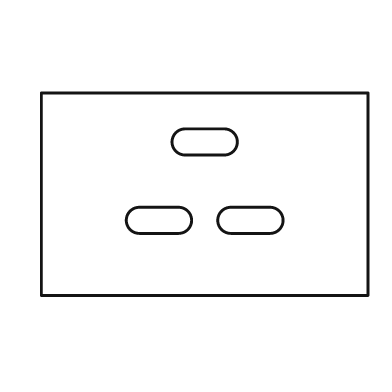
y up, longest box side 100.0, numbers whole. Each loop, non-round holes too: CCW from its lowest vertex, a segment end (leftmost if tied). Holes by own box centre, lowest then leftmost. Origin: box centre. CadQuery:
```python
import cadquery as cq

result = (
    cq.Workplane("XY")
    .moveTo(-50.0, -31.0)
    .lineTo(50.0, -31.0)
    .lineTo(50.0, 31.0)
    .lineTo(-50.0, 31.0)
    .close()
    .moveTo(-20.0, -12.0)
    .lineTo(-8.0, -12.0)
    .threePointArc((-4.0, -8.0), (-8.0, -4.0))
    .lineTo(-20.0, -4.0)
    .threePointArc((-24.0, -8.0), (-20.0, -12.0))
    .close()
    .moveTo(8.0, -12.0)
    .lineTo(20.0, -12.0)
    .threePointArc((24.0, -8.0), (20.0, -4.0))
    .lineTo(8.0, -4.0)
    .threePointArc((4.0, -8.0), (8.0, -12.0))
    .close()
    .moveTo(-6.0, 12.0)
    .lineTo(6.0, 12.0)
    .threePointArc((10.0, 16.0), (6.0, 20.0))
    .lineTo(-6.0, 20.0)
    .threePointArc((-10.0, 16.0), (-6.0, 12.0))
    .close()
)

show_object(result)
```